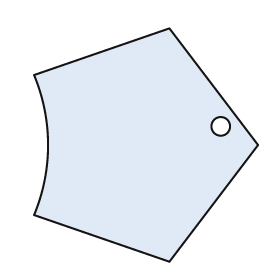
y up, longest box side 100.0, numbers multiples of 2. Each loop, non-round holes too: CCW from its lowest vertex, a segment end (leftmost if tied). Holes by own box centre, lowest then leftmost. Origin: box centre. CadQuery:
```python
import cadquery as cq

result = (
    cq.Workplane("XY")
    .moveTo(10.0, -50.0)
    .lineTo(48.0, 0.0)
    .lineTo(10.0, 50.0)
    .lineTo(-48.0, 30.0)
    .threePointArc((-42.0, 0.0), (-48.0, -30.0))
    .close()
    .moveTo(32.0, 8.0)
    .circle(4.0)
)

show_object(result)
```